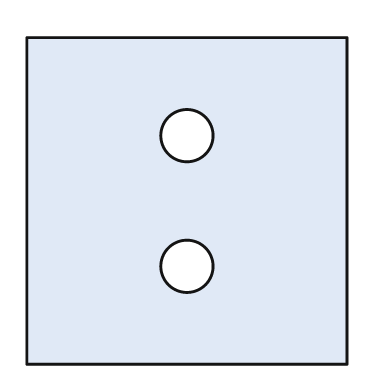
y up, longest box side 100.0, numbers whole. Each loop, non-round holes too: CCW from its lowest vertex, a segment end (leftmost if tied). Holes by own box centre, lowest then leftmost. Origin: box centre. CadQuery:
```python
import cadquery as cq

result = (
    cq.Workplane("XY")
    .moveTo(-49.0, -50.0)
    .lineTo(49.0, -50.0)
    .lineTo(49.0, 50.0)
    .lineTo(-49.0, 50.0)
    .close()
    .moveTo(0.0, -20.0)
    .circle(8.0)
    .moveTo(0.0, 20.0)
    .circle(8.0)
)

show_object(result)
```